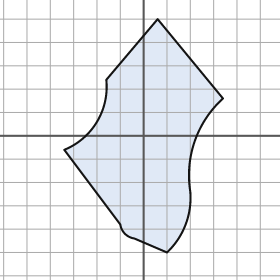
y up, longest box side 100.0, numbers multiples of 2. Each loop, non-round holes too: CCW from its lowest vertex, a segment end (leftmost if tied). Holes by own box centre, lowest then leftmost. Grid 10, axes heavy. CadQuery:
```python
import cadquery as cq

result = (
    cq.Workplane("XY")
    .moveTo(10.0, -50.0)
    .threePointArc((18.0, -38.0), (20.0, -24.0))
    .threePointArc((22.0, -2.0), (34.0, 16.0))
    .lineTo(6.0, 50.0)
    .lineTo(-16.0, 24.0)
    .threePointArc((-20.0, 6.0), (-34.0, -6.0))
    .lineTo(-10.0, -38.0)
    .threePointArc((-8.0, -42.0), (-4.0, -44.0))
    .close()
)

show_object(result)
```